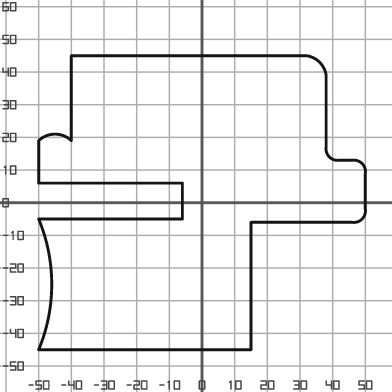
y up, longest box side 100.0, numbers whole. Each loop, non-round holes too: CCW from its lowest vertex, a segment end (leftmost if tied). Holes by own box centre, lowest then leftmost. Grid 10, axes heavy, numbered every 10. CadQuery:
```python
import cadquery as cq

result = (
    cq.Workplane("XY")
    .moveTo(-50.0, -45.0)
    .lineTo(15.0, -45.0)
    .lineTo(15.0, -6.0)
    .lineTo(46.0, -6.0)
    .threePointArc((49.0, -5.0), (50.0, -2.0))
    .lineTo(50.0, 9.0)
    .threePointArc((49.0, 12.0), (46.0, 13.0))
    .lineTo(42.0, 13.0)
    .threePointArc((39.0, 14.0), (38.0, 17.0))
    .lineTo(38.0, 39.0)
    .threePointArc((36.0, 43.0), (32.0, 45.0))
    .lineTo(-40.0, 45.0)
    .lineTo(-40.0, 19.0)
    .threePointArc((-45.0, 21.0), (-50.0, 19.0))
    .lineTo(-50.0, 6.0)
    .lineTo(-6.0, 6.0)
    .lineTo(-6.0, -5.0)
    .lineTo(-50.0, -5.0)
    .threePointArc((-46.0, -25.0), (-50.0, -45.0))
    .close()
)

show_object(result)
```